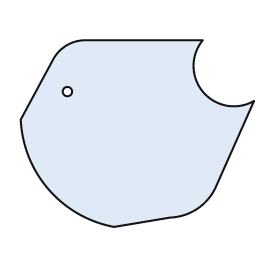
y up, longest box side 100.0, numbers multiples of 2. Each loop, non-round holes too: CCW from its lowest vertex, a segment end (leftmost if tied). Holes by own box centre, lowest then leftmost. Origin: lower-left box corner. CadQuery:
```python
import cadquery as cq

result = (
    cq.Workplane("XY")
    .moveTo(40.0, 0.0)
    .lineTo(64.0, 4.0)
    .threePointArc((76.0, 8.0), (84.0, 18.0))
    .lineTo(100.0, 54.0)
    .threePointArc((78.0, 58.0), (78.0, 80.0))
    .lineTo(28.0, 80.0)
    .threePointArc((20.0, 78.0), (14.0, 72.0))
    .lineTo(0.0, 46.0)
    .threePointArc((12.0, 16.0), (40.0, 0.0))
    .close()
    .moveTo(20.0, 58.0)
    .circle(2.0)
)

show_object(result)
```